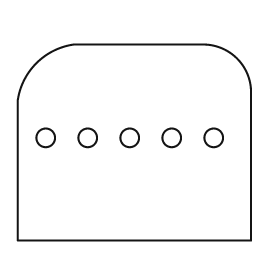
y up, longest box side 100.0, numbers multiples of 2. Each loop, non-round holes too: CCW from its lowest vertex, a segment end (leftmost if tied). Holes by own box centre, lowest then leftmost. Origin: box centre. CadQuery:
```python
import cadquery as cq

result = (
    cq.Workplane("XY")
    .moveTo(-50.0, -42.0)
    .lineTo(50.0, -42.0)
    .lineTo(50.0, 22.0)
    .threePointArc((44.0, 36.0), (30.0, 42.0))
    .lineTo(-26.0, 42.0)
    .threePointArc((-42.0, 34.0), (-50.0, 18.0))
    .close()
    .moveTo(-38.0, 2.0)
    .circle(4.0)
    .moveTo(-20.0, 2.0)
    .circle(4.0)
    .moveTo(-2.0, 2.0)
    .circle(4.0)
    .moveTo(16.0, 2.0)
    .circle(4.0)
    .moveTo(34.0, 2.0)
    .circle(4.0)
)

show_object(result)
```